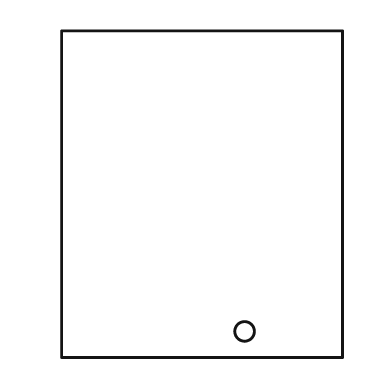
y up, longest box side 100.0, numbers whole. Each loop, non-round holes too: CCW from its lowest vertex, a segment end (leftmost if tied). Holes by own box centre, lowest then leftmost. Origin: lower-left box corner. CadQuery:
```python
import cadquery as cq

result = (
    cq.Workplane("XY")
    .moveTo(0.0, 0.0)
    .lineTo(86.0, 0.0)
    .lineTo(86.0, 100.0)
    .lineTo(0.0, 100.0)
    .close()
    .moveTo(56.0, 8.0)
    .circle(3.0)
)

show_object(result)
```